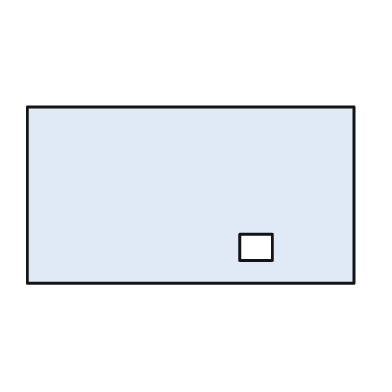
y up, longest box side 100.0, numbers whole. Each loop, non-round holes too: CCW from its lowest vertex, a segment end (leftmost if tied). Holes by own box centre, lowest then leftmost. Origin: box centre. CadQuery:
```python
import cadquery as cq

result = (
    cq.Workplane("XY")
    .moveTo(-50.0, -27.0)
    .lineTo(50.0, -27.0)
    .lineTo(50.0, 27.0)
    .lineTo(-50.0, 27.0)
    .close()
    .moveTo(15.0, -20.0)
    .lineTo(25.0, -20.0)
    .lineTo(25.0, -12.0)
    .lineTo(15.0, -12.0)
    .close()
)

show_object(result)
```